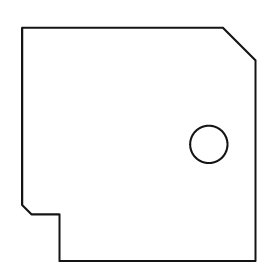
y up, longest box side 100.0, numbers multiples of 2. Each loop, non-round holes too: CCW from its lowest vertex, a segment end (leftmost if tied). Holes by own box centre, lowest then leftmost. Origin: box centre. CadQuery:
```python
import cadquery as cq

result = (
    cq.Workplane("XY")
    .moveTo(-34.0, -50.0)
    .lineTo(50.0, -50.0)
    .lineTo(50.0, 36.0)
    .lineTo(36.0, 50.0)
    .lineTo(-50.0, 50.0)
    .lineTo(-50.0, -26.0)
    .lineTo(-46.0, -30.0)
    .lineTo(-34.0, -30.0)
    .close()
    .moveTo(30.0, 0.0)
    .circle(8.0)
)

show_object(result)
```